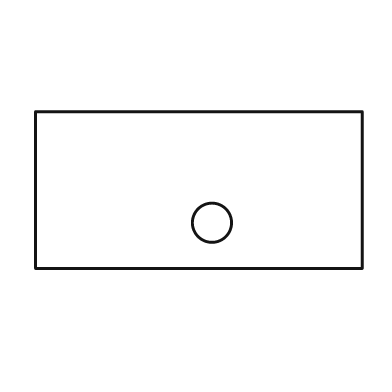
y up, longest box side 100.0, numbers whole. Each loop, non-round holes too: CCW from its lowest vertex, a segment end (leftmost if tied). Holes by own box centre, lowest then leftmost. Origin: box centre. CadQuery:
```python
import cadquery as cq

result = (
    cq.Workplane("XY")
    .moveTo(-50.0, -24.0)
    .lineTo(50.0, -24.0)
    .lineTo(50.0, 24.0)
    .lineTo(-50.0, 24.0)
    .close()
    .moveTo(4.0, -10.0)
    .circle(6.0)
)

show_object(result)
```